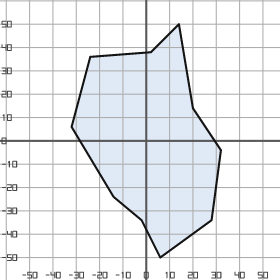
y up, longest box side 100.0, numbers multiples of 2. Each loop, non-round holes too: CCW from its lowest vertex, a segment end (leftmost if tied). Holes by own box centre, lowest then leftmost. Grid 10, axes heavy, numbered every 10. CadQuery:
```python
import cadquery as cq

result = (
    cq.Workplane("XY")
    .moveTo(6.0, -50.0)
    .lineTo(28.0, -34.0)
    .lineTo(32.0, -4.0)
    .lineTo(20.0, 14.0)
    .lineTo(14.0, 50.0)
    .lineTo(2.0, 38.0)
    .lineTo(-24.0, 36.0)
    .lineTo(-32.0, 6.0)
    .lineTo(-14.0, -24.0)
    .lineTo(-2.0, -34.0)
    .close()
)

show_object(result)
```